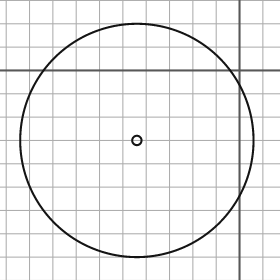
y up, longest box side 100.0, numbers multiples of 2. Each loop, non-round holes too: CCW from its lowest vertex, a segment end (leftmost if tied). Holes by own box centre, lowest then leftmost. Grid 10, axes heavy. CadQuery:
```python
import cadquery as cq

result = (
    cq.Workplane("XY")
    .moveTo(-44.0, -30.0)
    .circle(50.0)
    .moveTo(-44.0, -30.0)
    .circle(2.0)
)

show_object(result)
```